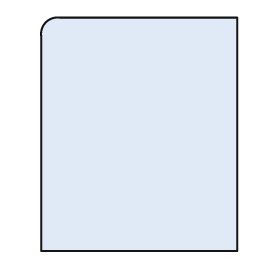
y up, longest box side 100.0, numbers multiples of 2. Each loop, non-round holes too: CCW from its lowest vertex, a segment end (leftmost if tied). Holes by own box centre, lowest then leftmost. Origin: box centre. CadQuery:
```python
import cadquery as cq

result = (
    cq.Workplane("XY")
    .moveTo(-42.0, -50.0)
    .lineTo(42.0, -50.0)
    .lineTo(42.0, 50.0)
    .lineTo(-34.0, 50.0)
    .threePointArc((-40.0, 48.0), (-42.0, 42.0))
    .close()
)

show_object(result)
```